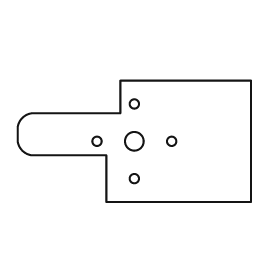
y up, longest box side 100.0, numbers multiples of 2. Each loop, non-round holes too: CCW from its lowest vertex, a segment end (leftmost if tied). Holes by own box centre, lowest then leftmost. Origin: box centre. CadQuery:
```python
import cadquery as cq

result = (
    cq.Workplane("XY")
    .moveTo(-12.0, -26.0)
    .lineTo(50.0, -26.0)
    .lineTo(50.0, 26.0)
    .lineTo(-6.0, 26.0)
    .lineTo(-6.0, 12.0)
    .lineTo(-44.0, 12.0)
    .threePointArc((-48.0, 10.0), (-50.0, 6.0))
    .lineTo(-50.0, 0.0)
    .threePointArc((-48.0, -4.0), (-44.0, -6.0))
    .lineTo(-12.0, -6.0)
    .close()
    .moveTo(0.0, -16.0)
    .circle(2.0)
    .moveTo(-16.0, 0.0)
    .circle(2.0)
    .moveTo(0.0, 0.0)
    .circle(4.0)
    .moveTo(16.0, 0.0)
    .circle(2.0)
    .moveTo(0.0, 16.0)
    .circle(2.0)
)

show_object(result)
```